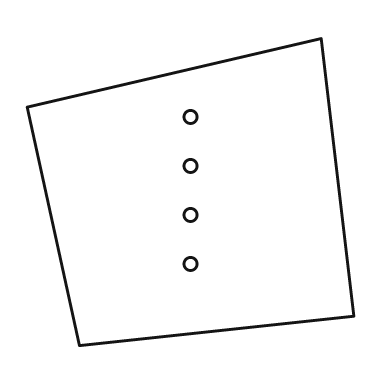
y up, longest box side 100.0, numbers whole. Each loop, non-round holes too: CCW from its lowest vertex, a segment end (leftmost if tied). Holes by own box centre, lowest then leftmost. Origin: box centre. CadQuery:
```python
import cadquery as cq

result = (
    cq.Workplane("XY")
    .moveTo(-34.0, -47.0)
    .lineTo(50.0, -38.0)
    .lineTo(40.0, 47.0)
    .lineTo(-50.0, 26.0)
    .close()
    .moveTo(0.0, -22.0)
    .circle(2.0)
    .moveTo(0.0, -7.0)
    .circle(2.0)
    .moveTo(0.0, 8.0)
    .circle(2.0)
    .moveTo(0.0, 23.0)
    .circle(2.0)
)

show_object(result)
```